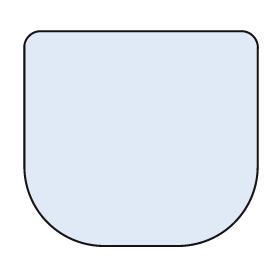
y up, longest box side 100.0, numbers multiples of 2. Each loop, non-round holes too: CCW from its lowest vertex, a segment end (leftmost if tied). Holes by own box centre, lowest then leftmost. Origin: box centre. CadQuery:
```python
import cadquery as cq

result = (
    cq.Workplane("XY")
    .moveTo(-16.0, -46.0)
    .lineTo(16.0, -46.0)
    .threePointArc((40.0, -36.0), (50.0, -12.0))
    .lineTo(50.0, 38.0)
    .threePointArc((48.0, 44.0), (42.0, 46.0))
    .lineTo(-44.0, 46.0)
    .threePointArc((-48.0, 44.0), (-50.0, 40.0))
    .lineTo(-50.0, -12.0)
    .threePointArc((-40.0, -36.0), (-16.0, -46.0))
    .close()
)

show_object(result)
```